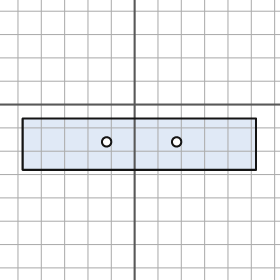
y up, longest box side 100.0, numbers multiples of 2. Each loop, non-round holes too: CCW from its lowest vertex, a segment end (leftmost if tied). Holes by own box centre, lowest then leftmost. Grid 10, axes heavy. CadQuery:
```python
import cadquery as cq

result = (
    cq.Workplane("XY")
    .moveTo(-48.0, -28.0)
    .lineTo(52.0, -28.0)
    .lineTo(52.0, -6.0)
    .lineTo(-48.0, -6.0)
    .close()
    .moveTo(-12.0, -16.0)
    .circle(2.0)
    .moveTo(18.0, -16.0)
    .circle(2.0)
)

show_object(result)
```